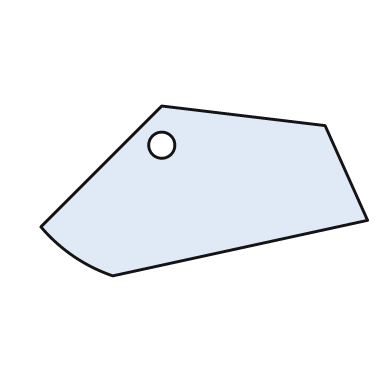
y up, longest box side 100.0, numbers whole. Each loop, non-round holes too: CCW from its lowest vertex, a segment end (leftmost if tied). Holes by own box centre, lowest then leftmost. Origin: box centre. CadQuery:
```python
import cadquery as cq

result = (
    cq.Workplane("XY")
    .moveTo(-28.0, -26.0)
    .lineTo(50.0, -9.0)
    .lineTo(37.0, 20.0)
    .lineTo(-13.0, 26.0)
    .lineTo(-50.0, -11.0)
    .threePointArc((-40.0, -20.0), (-28.0, -26.0))
    .close()
    .moveTo(-13.0, 14.0)
    .circle(4.0)
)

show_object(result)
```